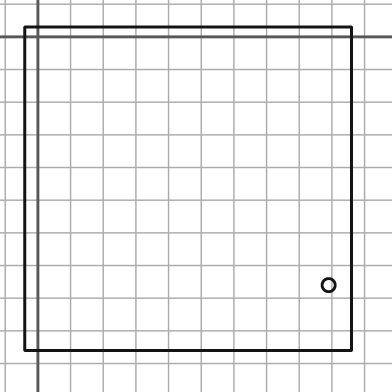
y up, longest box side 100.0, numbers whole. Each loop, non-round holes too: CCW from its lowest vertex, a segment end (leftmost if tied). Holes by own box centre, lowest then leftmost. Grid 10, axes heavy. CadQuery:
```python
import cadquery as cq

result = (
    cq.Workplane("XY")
    .moveTo(-4.0, -96.0)
    .lineTo(96.0, -96.0)
    .lineTo(96.0, 3.0)
    .lineTo(-4.0, 3.0)
    .close()
    .moveTo(89.0, -76.0)
    .circle(2.0)
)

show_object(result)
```